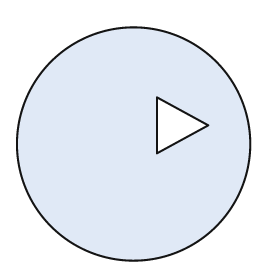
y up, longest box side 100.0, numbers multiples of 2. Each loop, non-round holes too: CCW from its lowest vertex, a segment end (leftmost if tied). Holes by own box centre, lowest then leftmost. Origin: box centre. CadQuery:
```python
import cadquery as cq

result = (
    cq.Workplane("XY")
    .moveTo(0.0, 0.0)
    .circle(50.0)
    .moveTo(10.0, -4.0)
    .lineTo(32.0, 8.0)
    .lineTo(10.0, 20.0)
    .close()
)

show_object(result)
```